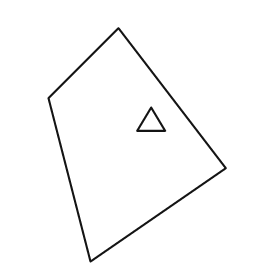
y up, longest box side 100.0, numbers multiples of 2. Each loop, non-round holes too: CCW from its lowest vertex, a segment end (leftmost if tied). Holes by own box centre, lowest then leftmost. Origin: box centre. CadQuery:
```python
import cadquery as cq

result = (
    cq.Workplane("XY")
    .moveTo(-20.0, -50.0)
    .lineTo(38.0, -10.0)
    .lineTo(-8.0, 50.0)
    .lineTo(-38.0, 20.0)
    .close()
    .moveTo(0.0, 6.0)
    .lineTo(12.0, 6.0)
    .lineTo(6.0, 16.0)
    .close()
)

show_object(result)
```